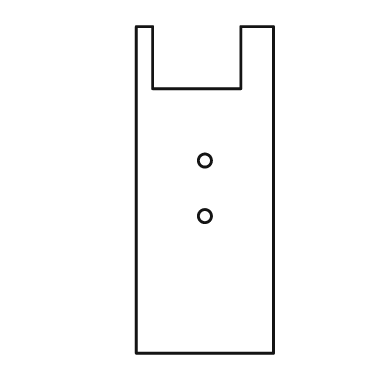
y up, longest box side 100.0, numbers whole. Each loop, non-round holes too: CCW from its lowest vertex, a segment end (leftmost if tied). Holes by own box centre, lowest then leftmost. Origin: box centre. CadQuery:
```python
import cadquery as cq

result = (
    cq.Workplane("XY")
    .moveTo(-21.0, -50.0)
    .lineTo(21.0, -50.0)
    .lineTo(21.0, 50.0)
    .lineTo(11.0, 50.0)
    .lineTo(11.0, 31.0)
    .lineTo(-16.0, 31.0)
    .lineTo(-16.0, 50.0)
    .lineTo(-21.0, 50.0)
    .close()
    .moveTo(0.0, -8.0)
    .circle(2.0)
    .moveTo(0.0, 9.0)
    .circle(2.0)
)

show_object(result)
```